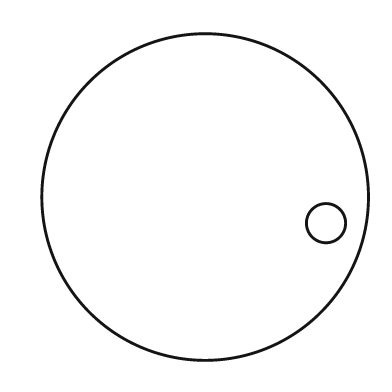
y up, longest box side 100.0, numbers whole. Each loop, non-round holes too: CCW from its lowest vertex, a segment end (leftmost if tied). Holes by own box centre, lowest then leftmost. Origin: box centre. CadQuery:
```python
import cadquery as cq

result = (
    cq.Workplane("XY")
    .moveTo(0.0, 0.0)
    .circle(50.0)
    .moveTo(37.0, -8.0)
    .circle(6.0)
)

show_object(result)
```